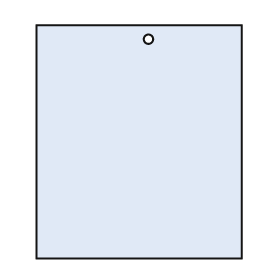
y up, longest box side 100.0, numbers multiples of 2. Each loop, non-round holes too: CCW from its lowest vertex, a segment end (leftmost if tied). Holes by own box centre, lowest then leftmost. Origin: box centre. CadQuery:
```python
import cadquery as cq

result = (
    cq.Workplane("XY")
    .moveTo(-44.0, -50.0)
    .lineTo(44.0, -50.0)
    .lineTo(44.0, 50.0)
    .lineTo(-44.0, 50.0)
    .close()
    .moveTo(4.0, 44.0)
    .circle(2.0)
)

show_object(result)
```